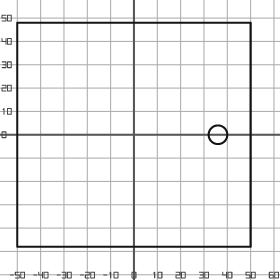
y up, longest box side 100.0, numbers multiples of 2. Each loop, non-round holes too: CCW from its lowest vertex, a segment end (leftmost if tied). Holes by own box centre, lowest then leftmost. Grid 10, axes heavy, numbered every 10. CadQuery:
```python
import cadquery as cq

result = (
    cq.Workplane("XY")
    .moveTo(-50.0, -48.0)
    .lineTo(50.0, -48.0)
    .lineTo(50.0, 48.0)
    .lineTo(-50.0, 48.0)
    .close()
    .moveTo(36.0, 0.0)
    .circle(4.0)
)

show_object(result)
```